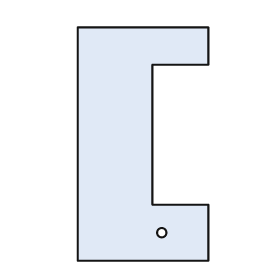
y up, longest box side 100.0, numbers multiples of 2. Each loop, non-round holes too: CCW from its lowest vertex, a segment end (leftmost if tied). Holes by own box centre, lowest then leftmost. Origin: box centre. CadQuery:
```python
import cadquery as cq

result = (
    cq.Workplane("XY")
    .moveTo(-28.0, -50.0)
    .lineTo(28.0, -50.0)
    .lineTo(28.0, -26.0)
    .lineTo(4.0, -26.0)
    .lineTo(4.0, 34.0)
    .lineTo(28.0, 34.0)
    .lineTo(28.0, 50.0)
    .lineTo(-28.0, 50.0)
    .close()
    .moveTo(8.0, -38.0)
    .circle(2.0)
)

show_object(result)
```